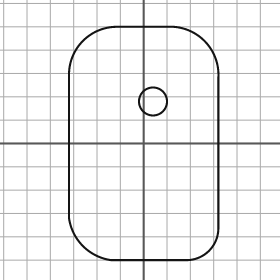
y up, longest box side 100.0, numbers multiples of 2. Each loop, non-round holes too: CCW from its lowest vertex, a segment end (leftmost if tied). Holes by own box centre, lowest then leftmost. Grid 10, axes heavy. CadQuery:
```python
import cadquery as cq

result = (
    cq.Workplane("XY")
    .moveTo(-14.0, -50.0)
    .lineTo(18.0, -50.0)
    .threePointArc((28.0, -46.0), (32.0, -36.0))
    .lineTo(32.0, 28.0)
    .threePointArc((26.0, 44.0), (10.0, 50.0))
    .lineTo(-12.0, 50.0)
    .threePointArc((-26.0, 44.0), (-32.0, 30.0))
    .lineTo(-32.0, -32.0)
    .threePointArc((-26.0, -44.0), (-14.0, -50.0))
    .close()
    .moveTo(4.0, 18.0)
    .circle(6.0)
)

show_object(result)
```